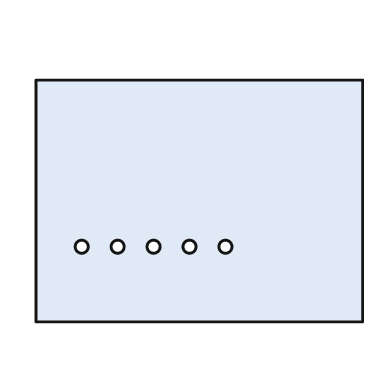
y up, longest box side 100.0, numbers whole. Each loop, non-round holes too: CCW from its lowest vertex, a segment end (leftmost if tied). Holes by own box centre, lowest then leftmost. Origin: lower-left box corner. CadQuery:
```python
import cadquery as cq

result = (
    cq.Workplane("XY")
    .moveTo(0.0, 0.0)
    .lineTo(100.0, 0.0)
    .lineTo(100.0, 74.0)
    .lineTo(0.0, 74.0)
    .close()
    .moveTo(14.0, 23.0)
    .circle(2.0)
    .moveTo(25.0, 23.0)
    .circle(2.0)
    .moveTo(36.0, 23.0)
    .circle(2.0)
    .moveTo(47.0, 23.0)
    .circle(2.0)
    .moveTo(58.0, 23.0)
    .circle(2.0)
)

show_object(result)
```